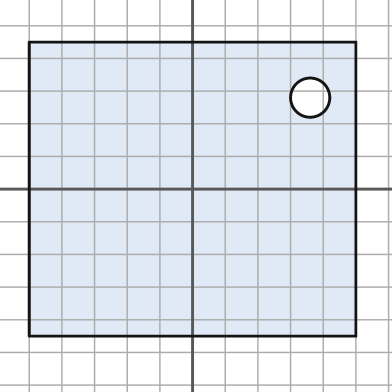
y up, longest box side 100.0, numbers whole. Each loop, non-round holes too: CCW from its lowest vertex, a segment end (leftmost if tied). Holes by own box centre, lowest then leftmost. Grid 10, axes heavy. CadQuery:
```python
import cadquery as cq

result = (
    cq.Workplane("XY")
    .moveTo(-50.0, -45.0)
    .lineTo(50.0, -45.0)
    .lineTo(50.0, 45.0)
    .lineTo(-50.0, 45.0)
    .close()
    .moveTo(36.0, 28.0)
    .circle(6.0)
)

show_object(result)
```